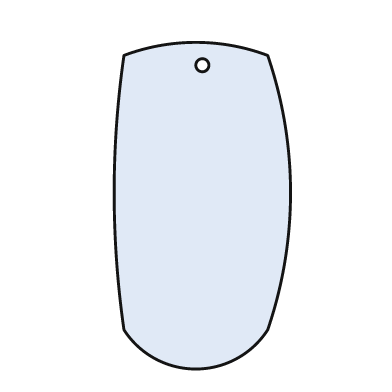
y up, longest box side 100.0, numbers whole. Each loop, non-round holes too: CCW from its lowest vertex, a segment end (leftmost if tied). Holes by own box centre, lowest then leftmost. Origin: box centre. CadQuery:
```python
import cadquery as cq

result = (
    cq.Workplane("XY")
    .moveTo(-24.0, -38.0)
    .threePointArc((-2.0, -50.0), (20.0, -38.0))
    .threePointArc((27.0, 4.0), (20.0, 46.0))
    .threePointArc((-2.0, 50.0), (-24.0, 46.0))
    .threePointArc((-27.0, 4.0), (-24.0, -38.0))
    .close()
    .moveTo(0.0, 43.0)
    .circle(2.0)
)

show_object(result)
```